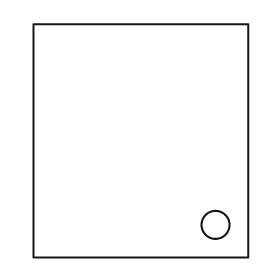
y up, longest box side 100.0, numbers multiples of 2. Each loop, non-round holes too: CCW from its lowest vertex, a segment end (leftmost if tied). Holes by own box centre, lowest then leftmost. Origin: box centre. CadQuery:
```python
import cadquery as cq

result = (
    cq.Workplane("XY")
    .moveTo(-46.0, -50.0)
    .lineTo(46.0, -50.0)
    .lineTo(46.0, 50.0)
    .lineTo(-46.0, 50.0)
    .close()
    .moveTo(32.0, -36.0)
    .circle(6.0)
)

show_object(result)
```